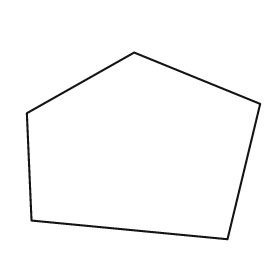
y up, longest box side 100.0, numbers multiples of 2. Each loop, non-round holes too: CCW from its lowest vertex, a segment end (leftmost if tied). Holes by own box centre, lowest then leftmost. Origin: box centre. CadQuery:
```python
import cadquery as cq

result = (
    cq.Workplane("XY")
    .moveTo(36.0, -40.0)
    .lineTo(50.0, 18.0)
    .lineTo(-4.0, 40.0)
    .lineTo(-50.0, 14.0)
    .lineTo(-48.0, -32.0)
    .close()
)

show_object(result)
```